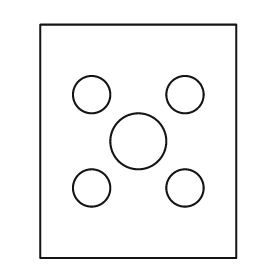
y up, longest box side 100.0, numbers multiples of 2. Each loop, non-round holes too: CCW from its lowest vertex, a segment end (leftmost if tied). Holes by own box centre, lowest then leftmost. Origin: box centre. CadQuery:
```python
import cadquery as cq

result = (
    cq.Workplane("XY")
    .moveTo(-42.0, -50.0)
    .lineTo(42.0, -50.0)
    .lineTo(42.0, 50.0)
    .lineTo(-42.0, 50.0)
    .close()
    .moveTo(-20.0, -20.0)
    .circle(8.0)
    .moveTo(20.0, -20.0)
    .circle(8.0)
    .moveTo(0.0, 0.0)
    .circle(12.0)
    .moveTo(-20.0, 20.0)
    .circle(8.0)
    .moveTo(20.0, 20.0)
    .circle(8.0)
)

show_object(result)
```